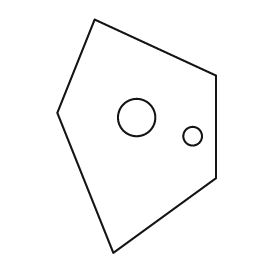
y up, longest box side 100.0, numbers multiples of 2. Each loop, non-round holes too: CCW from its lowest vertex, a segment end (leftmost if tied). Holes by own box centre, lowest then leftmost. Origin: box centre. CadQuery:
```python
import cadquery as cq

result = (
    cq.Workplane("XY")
    .moveTo(-10.0, -50.0)
    .lineTo(34.0, -18.0)
    .lineTo(34.0, 26.0)
    .lineTo(-18.0, 50.0)
    .lineTo(-34.0, 10.0)
    .close()
    .moveTo(24.0, 0.0)
    .circle(4.0)
    .moveTo(0.0, 8.0)
    .circle(8.0)
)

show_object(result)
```